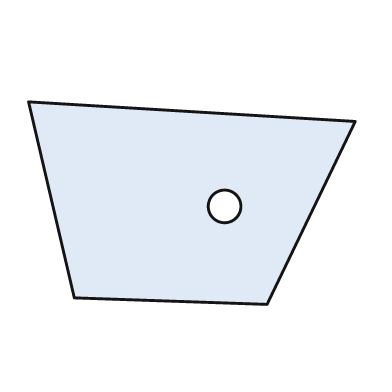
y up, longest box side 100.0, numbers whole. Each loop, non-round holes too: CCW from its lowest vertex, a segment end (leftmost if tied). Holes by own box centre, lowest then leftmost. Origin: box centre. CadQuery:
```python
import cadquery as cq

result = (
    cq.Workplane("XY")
    .moveTo(23.0, -31.0)
    .lineTo(50.0, 25.0)
    .lineTo(-50.0, 31.0)
    .lineTo(-36.0, -29.0)
    .close()
    .moveTo(10.0, -1.0)
    .circle(5.0)
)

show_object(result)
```